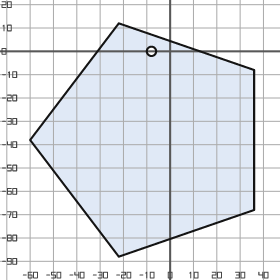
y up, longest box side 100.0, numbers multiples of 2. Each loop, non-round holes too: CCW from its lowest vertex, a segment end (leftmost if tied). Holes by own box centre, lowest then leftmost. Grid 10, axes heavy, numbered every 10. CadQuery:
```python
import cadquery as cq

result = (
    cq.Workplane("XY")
    .moveTo(-22.0, -88.0)
    .lineTo(36.0, -68.0)
    .lineTo(36.0, -8.0)
    .lineTo(-22.0, 12.0)
    .lineTo(-60.0, -38.0)
    .close()
    .moveTo(-8.0, 0.0)
    .circle(2.0)
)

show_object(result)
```